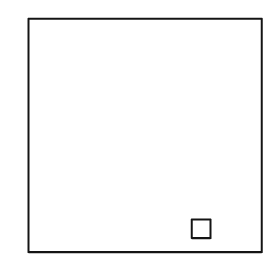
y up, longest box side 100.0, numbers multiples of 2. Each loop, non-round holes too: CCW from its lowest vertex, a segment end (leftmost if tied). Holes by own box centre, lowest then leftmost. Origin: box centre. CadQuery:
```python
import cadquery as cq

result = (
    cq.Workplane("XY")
    .moveTo(-50.0, -50.0)
    .lineTo(50.0, -50.0)
    .lineTo(50.0, 50.0)
    .lineTo(-50.0, 50.0)
    .close()
    .moveTo(20.0, -44.0)
    .lineTo(28.0, -44.0)
    .lineTo(28.0, -36.0)
    .lineTo(20.0, -36.0)
    .close()
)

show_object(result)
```